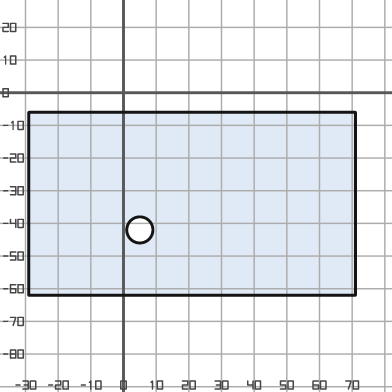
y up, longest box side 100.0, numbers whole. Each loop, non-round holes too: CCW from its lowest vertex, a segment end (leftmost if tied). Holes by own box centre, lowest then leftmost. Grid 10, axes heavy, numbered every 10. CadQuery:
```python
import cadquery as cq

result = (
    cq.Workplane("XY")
    .moveTo(-29.0, -62.0)
    .lineTo(71.0, -62.0)
    .lineTo(71.0, -6.0)
    .lineTo(-29.0, -6.0)
    .close()
    .moveTo(5.0, -42.0)
    .circle(4.0)
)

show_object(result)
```